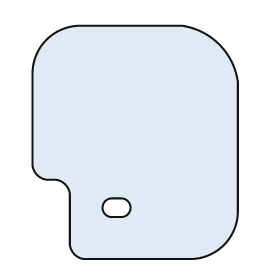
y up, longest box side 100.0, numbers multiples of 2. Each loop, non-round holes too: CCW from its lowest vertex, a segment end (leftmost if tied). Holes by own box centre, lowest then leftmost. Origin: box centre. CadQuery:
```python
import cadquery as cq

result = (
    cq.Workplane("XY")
    .moveTo(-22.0, -50.0)
    .lineTo(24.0, -50.0)
    .threePointArc((38.0, -44.0), (44.0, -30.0))
    .lineTo(44.0, 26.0)
    .threePointArc((36.0, 42.0), (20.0, 50.0))
    .lineTo(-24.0, 50.0)
    .threePointArc((-38.0, 44.0), (-44.0, 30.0))
    .lineTo(-44.0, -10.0)
    .threePointArc((-42.0, -14.0), (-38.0, -16.0))
    .lineTo(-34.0, -16.0)
    .threePointArc((-30.0, -18.0), (-28.0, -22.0))
    .lineTo(-28.0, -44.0)
    .threePointArc((-26.0, -48.0), (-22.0, -50.0))
    .close()
    .moveTo(-10.0, -32.0)
    .lineTo(-6.0, -32.0)
    .threePointArc((-2.0, -28.0), (-6.0, -24.0))
    .lineTo(-10.0, -24.0)
    .threePointArc((-14.0, -28.0), (-10.0, -32.0))
    .close()
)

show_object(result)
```